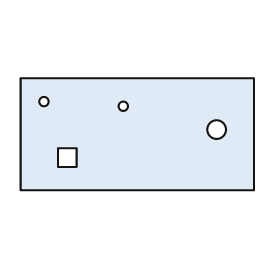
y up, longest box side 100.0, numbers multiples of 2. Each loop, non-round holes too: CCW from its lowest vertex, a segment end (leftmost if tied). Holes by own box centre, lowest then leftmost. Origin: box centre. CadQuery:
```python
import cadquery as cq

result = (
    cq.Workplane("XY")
    .moveTo(-50.0, -24.0)
    .lineTo(50.0, -24.0)
    .lineTo(50.0, 24.0)
    .lineTo(-50.0, 24.0)
    .close()
    .moveTo(-34.0, -14.0)
    .lineTo(-26.0, -14.0)
    .lineTo(-26.0, -6.0)
    .lineTo(-34.0, -6.0)
    .close()
    .moveTo(34.0, 2.0)
    .circle(4.0)
    .moveTo(-6.0, 12.0)
    .circle(2.0)
    .moveTo(-40.0, 14.0)
    .circle(2.0)
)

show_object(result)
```